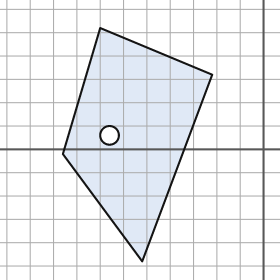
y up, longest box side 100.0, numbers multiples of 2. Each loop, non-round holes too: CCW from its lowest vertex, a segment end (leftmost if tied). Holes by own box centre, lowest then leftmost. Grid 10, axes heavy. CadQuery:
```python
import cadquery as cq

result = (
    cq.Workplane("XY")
    .moveTo(-52.0, -48.0)
    .lineTo(-22.0, 32.0)
    .lineTo(-70.0, 52.0)
    .lineTo(-86.0, -2.0)
    .close()
    .moveTo(-66.0, 6.0)
    .circle(4.0)
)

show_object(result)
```